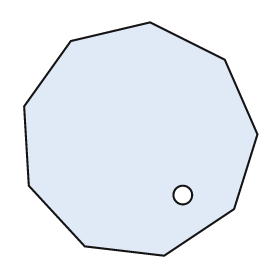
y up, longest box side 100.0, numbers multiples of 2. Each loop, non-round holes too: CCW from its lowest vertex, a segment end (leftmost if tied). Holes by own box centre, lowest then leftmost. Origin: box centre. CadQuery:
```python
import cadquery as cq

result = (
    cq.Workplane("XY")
    .moveTo(10.0, -50.0)
    .lineTo(40.0, -30.0)
    .lineTo(50.0, 2.0)
    .lineTo(36.0, 34.0)
    .lineTo(4.0, 50.0)
    .lineTo(-30.0, 42.0)
    .lineTo(-50.0, 14.0)
    .lineTo(-48.0, -20.0)
    .lineTo(-24.0, -46.0)
    .close()
    .moveTo(18.0, -24.0)
    .circle(4.0)
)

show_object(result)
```